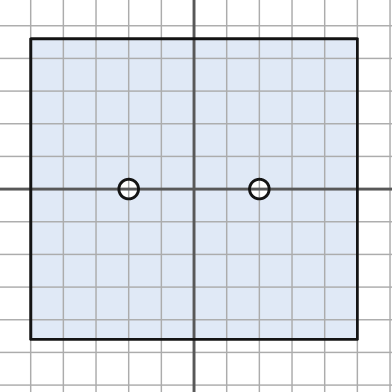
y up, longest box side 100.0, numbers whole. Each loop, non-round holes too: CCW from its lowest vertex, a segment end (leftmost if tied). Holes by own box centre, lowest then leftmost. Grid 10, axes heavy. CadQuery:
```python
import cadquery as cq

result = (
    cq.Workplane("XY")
    .moveTo(-50.0, -46.0)
    .lineTo(50.0, -46.0)
    .lineTo(50.0, 46.0)
    .lineTo(-50.0, 46.0)
    .close()
    .moveTo(-20.0, 0.0)
    .circle(3.0)
    .moveTo(20.0, 0.0)
    .circle(3.0)
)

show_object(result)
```